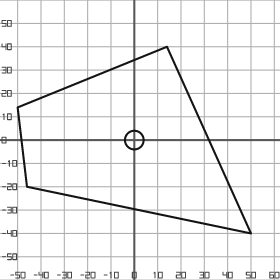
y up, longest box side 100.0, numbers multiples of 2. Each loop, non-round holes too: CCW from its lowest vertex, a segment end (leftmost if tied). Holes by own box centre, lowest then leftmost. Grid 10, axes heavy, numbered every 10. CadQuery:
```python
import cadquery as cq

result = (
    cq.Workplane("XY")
    .moveTo(50.0, -40.0)
    .lineTo(14.0, 40.0)
    .lineTo(-50.0, 14.0)
    .lineTo(-46.0, -20.0)
    .close()
    .moveTo(0.0, 0.0)
    .circle(4.0)
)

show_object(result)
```